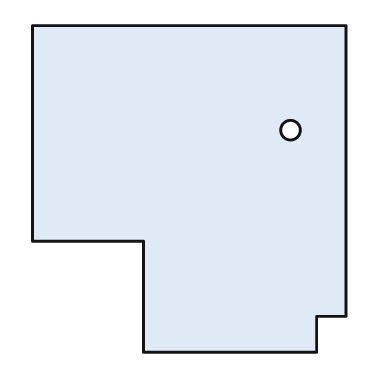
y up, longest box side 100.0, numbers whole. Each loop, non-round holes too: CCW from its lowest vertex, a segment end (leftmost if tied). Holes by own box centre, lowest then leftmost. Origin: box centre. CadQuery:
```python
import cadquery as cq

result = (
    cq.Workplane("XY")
    .moveTo(-14.0, -50.0)
    .lineTo(39.0, -50.0)
    .lineTo(39.0, -39.0)
    .lineTo(48.0, -39.0)
    .lineTo(48.0, 50.0)
    .lineTo(-48.0, 50.0)
    .lineTo(-48.0, -16.0)
    .lineTo(-14.0, -16.0)
    .close()
    .moveTo(31.0, 18.0)
    .circle(3.0)
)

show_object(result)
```